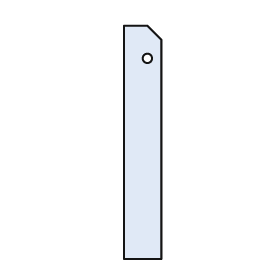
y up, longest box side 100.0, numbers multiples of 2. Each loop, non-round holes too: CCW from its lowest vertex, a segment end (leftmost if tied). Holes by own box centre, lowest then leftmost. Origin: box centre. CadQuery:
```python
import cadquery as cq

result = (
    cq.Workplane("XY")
    .moveTo(-8.0, -50.0)
    .lineTo(8.0, -50.0)
    .lineTo(8.0, 44.0)
    .lineTo(2.0, 50.0)
    .lineTo(-8.0, 50.0)
    .close()
    .moveTo(2.0, 36.0)
    .circle(2.0)
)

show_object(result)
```